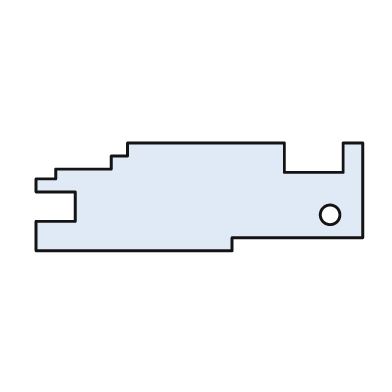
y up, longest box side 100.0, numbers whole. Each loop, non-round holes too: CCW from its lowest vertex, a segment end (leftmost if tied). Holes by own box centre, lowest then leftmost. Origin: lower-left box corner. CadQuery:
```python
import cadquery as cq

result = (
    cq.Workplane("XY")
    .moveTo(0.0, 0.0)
    .lineTo(60.0, 0.0)
    .lineTo(60.0, 4.0)
    .lineTo(100.0, 4.0)
    .lineTo(100.0, 33.0)
    .lineTo(94.0, 33.0)
    .lineTo(94.0, 24.0)
    .lineTo(76.0, 24.0)
    .lineTo(76.0, 33.0)
    .lineTo(28.0, 33.0)
    .lineTo(28.0, 29.0)
    .lineTo(23.0, 29.0)
    .lineTo(23.0, 25.0)
    .lineTo(6.0, 25.0)
    .lineTo(6.0, 22.0)
    .lineTo(0.0, 22.0)
    .lineTo(0.0, 18.0)
    .lineTo(12.0, 18.0)
    .lineTo(12.0, 9.0)
    .lineTo(0.0, 9.0)
    .close()
    .moveTo(90.0, 11.0)
    .circle(3.0)
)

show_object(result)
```